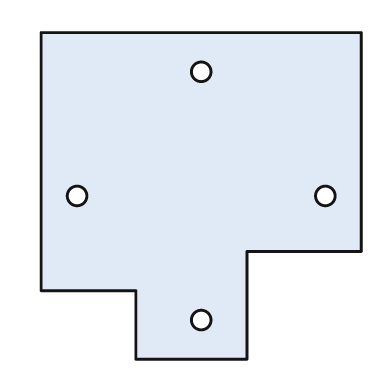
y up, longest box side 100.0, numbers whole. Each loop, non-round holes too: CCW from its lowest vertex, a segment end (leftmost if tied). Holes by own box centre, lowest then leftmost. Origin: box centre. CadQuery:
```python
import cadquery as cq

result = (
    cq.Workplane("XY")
    .moveTo(-20.0, -50.0)
    .lineTo(14.0, -50.0)
    .lineTo(14.0, -17.0)
    .lineTo(49.0, -17.0)
    .lineTo(49.0, 50.0)
    .lineTo(-49.0, 50.0)
    .lineTo(-49.0, -29.0)
    .lineTo(-20.0, -29.0)
    .close()
    .moveTo(0.0, -38.0)
    .circle(3.0)
    .moveTo(-38.0, 0.0)
    .circle(3.0)
    .moveTo(38.0, 0.0)
    .circle(3.0)
    .moveTo(0.0, 38.0)
    .circle(3.0)
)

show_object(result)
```